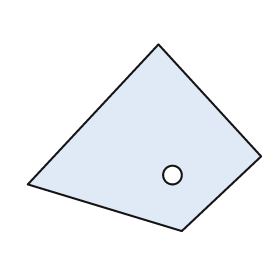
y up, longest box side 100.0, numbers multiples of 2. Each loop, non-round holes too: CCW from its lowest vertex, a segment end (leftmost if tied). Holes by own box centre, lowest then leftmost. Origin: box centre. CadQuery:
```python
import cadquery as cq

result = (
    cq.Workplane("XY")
    .moveTo(16.0, -40.0)
    .lineTo(50.0, -8.0)
    .lineTo(6.0, 40.0)
    .lineTo(-50.0, -20.0)
    .close()
    .moveTo(12.0, -16.0)
    .circle(4.0)
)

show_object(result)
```